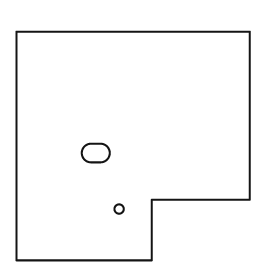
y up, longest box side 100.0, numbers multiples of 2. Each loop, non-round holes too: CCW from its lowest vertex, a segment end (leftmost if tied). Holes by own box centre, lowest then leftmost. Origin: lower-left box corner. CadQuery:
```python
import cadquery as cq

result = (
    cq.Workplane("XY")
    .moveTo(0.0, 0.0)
    .lineTo(58.0, 0.0)
    .lineTo(58.0, 26.0)
    .lineTo(100.0, 26.0)
    .lineTo(100.0, 98.0)
    .lineTo(0.0, 98.0)
    .close()
    .moveTo(44.0, 22.0)
    .circle(2.0)
    .moveTo(32.0, 42.0)
    .lineTo(36.0, 42.0)
    .threePointArc((40.0, 46.0), (36.0, 50.0))
    .lineTo(32.0, 50.0)
    .threePointArc((28.0, 46.0), (32.0, 42.0))
    .close()
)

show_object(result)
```